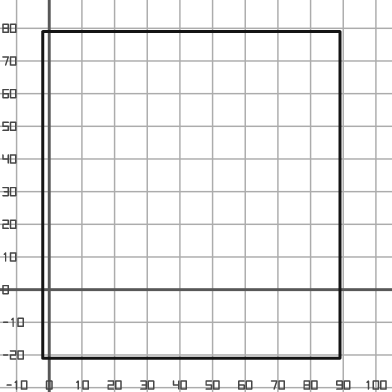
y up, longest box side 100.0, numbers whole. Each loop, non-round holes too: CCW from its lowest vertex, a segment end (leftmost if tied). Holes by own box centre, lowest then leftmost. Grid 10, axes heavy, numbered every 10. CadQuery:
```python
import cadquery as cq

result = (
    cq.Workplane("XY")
    .moveTo(-2.0, -21.0)
    .lineTo(89.0, -21.0)
    .lineTo(89.0, 79.0)
    .lineTo(-2.0, 79.0)
    .close()
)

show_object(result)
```